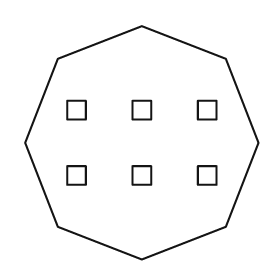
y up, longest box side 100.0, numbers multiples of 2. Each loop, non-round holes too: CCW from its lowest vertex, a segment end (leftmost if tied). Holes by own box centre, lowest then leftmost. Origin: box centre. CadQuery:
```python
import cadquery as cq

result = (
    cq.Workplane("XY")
    .moveTo(0.0, -50.0)
    .lineTo(36.0, -36.0)
    .lineTo(50.0, 0.0)
    .lineTo(36.0, 36.0)
    .lineTo(0.0, 50.0)
    .lineTo(-36.0, 36.0)
    .lineTo(-50.0, 0.0)
    .lineTo(-36.0, -36.0)
    .close()
    .moveTo(-32.0, -18.0)
    .lineTo(-24.0, -18.0)
    .lineTo(-24.0, -10.0)
    .lineTo(-32.0, -10.0)
    .close()
    .moveTo(-4.0, -18.0)
    .lineTo(4.0, -18.0)
    .lineTo(4.0, -10.0)
    .lineTo(-4.0, -10.0)
    .close()
    .moveTo(24.0, -18.0)
    .lineTo(32.0, -18.0)
    .lineTo(32.0, -10.0)
    .lineTo(24.0, -10.0)
    .close()
    .moveTo(-32.0, 10.0)
    .lineTo(-24.0, 10.0)
    .lineTo(-24.0, 18.0)
    .lineTo(-32.0, 18.0)
    .close()
    .moveTo(-4.0, 10.0)
    .lineTo(4.0, 10.0)
    .lineTo(4.0, 18.0)
    .lineTo(-4.0, 18.0)
    .close()
    .moveTo(24.0, 10.0)
    .lineTo(32.0, 10.0)
    .lineTo(32.0, 18.0)
    .lineTo(24.0, 18.0)
    .close()
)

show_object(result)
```